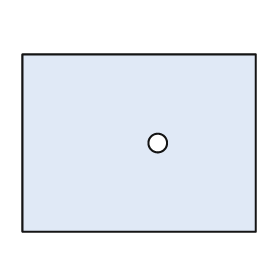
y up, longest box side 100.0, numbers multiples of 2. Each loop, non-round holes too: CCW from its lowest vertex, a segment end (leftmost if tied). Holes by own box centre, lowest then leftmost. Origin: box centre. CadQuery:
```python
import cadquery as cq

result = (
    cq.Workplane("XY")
    .moveTo(-50.0, -38.0)
    .lineTo(50.0, -38.0)
    .lineTo(50.0, 38.0)
    .lineTo(-50.0, 38.0)
    .close()
    .moveTo(8.0, 0.0)
    .circle(4.0)
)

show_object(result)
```